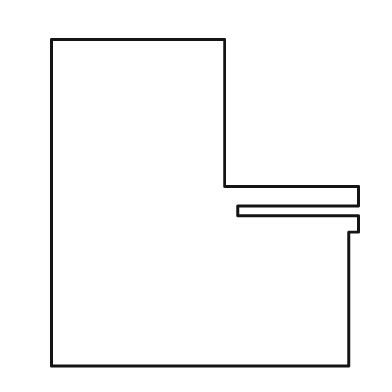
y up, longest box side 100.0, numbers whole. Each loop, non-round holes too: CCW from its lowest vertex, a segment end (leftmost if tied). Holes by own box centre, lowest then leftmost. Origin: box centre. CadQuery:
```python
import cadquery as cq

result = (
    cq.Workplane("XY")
    .moveTo(-47.0, -50.0)
    .lineTo(44.0, -50.0)
    .lineTo(44.0, -9.0)
    .lineTo(47.0, -9.0)
    .lineTo(47.0, -4.0)
    .lineTo(10.0, -4.0)
    .lineTo(10.0, -1.0)
    .lineTo(47.0, -1.0)
    .lineTo(47.0, 5.0)
    .lineTo(6.0, 5.0)
    .lineTo(6.0, 50.0)
    .lineTo(-47.0, 50.0)
    .close()
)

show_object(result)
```